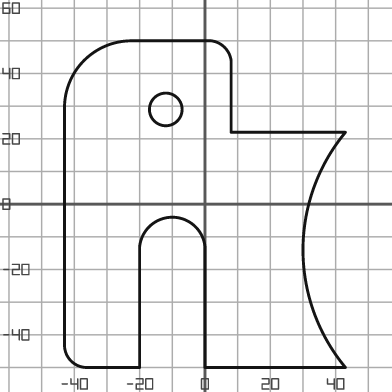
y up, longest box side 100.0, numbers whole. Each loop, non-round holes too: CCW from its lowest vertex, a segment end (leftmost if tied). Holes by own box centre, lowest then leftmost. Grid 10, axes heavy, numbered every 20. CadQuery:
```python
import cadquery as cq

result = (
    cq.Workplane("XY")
    .moveTo(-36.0, -50.0)
    .lineTo(-20.0, -50.0)
    .lineTo(-20.0, -13.0)
    .threePointArc((-10.0, -4.0), (0.0, -13.0))
    .lineTo(0.0, -50.0)
    .lineTo(43.0, -50.0)
    .threePointArc((30.0, -14.0), (43.0, 22.0))
    .lineTo(8.0, 22.0)
    .lineTo(8.0, 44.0)
    .threePointArc((6.0, 48.0), (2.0, 50.0))
    .lineTo(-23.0, 50.0)
    .threePointArc((-37.0, 44.0), (-43.0, 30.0))
    .lineTo(-43.0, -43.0)
    .threePointArc((-41.0, -48.0), (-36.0, -50.0))
    .close()
    .moveTo(-12.0, 29.0)
    .circle(5.0)
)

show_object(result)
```